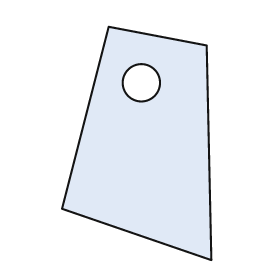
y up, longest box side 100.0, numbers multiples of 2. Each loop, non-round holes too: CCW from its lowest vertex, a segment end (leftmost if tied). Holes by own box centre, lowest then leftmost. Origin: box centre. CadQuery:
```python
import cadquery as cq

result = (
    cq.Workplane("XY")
    .moveTo(32.0, -50.0)
    .lineTo(30.0, 42.0)
    .lineTo(-12.0, 50.0)
    .lineTo(-32.0, -28.0)
    .close()
    .moveTo(2.0, 26.0)
    .circle(8.0)
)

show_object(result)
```